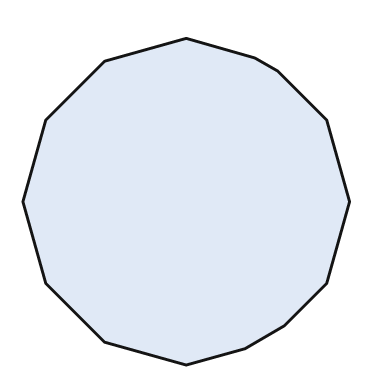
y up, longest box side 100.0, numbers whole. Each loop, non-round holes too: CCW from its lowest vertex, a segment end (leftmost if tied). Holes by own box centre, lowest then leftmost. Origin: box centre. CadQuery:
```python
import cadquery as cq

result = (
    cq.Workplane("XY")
    .moveTo(0.0, -50.0)
    .lineTo(18.0, -45.0)
    .lineTo(30.0, -38.0)
    .lineTo(43.0, -25.0)
    .lineTo(50.0, 0.0)
    .lineTo(43.0, 25.0)
    .lineTo(28.0, 40.0)
    .lineTo(21.0, 44.0)
    .lineTo(0.0, 50.0)
    .lineTo(-25.0, 43.0)
    .lineTo(-43.0, 25.0)
    .lineTo(-50.0, 0.0)
    .lineTo(-43.0, -25.0)
    .lineTo(-25.0, -43.0)
    .close()
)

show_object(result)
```